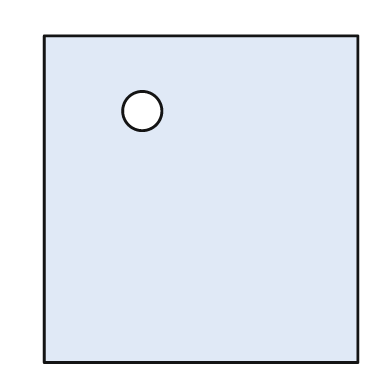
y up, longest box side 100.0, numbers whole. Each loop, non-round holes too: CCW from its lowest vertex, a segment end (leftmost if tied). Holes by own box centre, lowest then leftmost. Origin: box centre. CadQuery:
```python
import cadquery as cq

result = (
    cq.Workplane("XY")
    .moveTo(-48.0, -50.0)
    .lineTo(48.0, -50.0)
    .lineTo(48.0, 50.0)
    .lineTo(-48.0, 50.0)
    .close()
    .moveTo(-18.0, 27.0)
    .circle(6.0)
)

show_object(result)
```